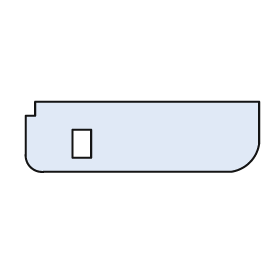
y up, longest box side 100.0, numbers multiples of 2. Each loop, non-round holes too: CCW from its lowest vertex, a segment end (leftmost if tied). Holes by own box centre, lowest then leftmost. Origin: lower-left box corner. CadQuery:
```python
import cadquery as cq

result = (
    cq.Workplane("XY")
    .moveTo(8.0, 0.0)
    .lineTo(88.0, 0.0)
    .threePointArc((96.0, 4.0), (100.0, 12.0))
    .lineTo(100.0, 30.0)
    .lineTo(4.0, 30.0)
    .lineTo(4.0, 24.0)
    .lineTo(0.0, 24.0)
    .lineTo(0.0, 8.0)
    .threePointArc((2.0, 2.0), (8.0, 0.0))
    .close()
    .moveTo(20.0, 6.0)
    .lineTo(28.0, 6.0)
    .lineTo(28.0, 18.0)
    .lineTo(20.0, 18.0)
    .close()
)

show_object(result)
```